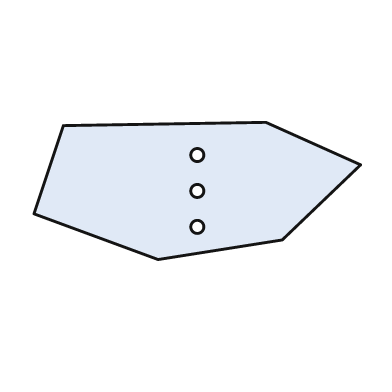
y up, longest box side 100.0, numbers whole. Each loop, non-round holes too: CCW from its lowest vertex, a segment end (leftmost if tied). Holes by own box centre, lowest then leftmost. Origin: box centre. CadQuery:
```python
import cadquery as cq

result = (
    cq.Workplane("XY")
    .moveTo(-12.0, -21.0)
    .lineTo(26.0, -15.0)
    .lineTo(50.0, 8.0)
    .lineTo(21.0, 21.0)
    .lineTo(-41.0, 20.0)
    .lineTo(-50.0, -7.0)
    .close()
    .moveTo(0.0, -11.0)
    .circle(2.0)
    .moveTo(0.0, 0.0)
    .circle(2.0)
    .moveTo(0.0, 11.0)
    .circle(2.0)
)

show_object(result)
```